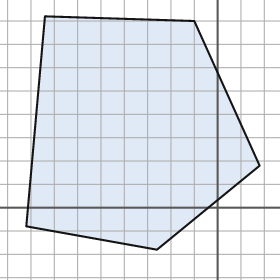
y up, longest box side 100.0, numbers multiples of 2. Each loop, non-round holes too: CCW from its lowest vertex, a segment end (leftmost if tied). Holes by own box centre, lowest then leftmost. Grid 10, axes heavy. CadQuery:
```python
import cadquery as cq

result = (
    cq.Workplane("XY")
    .moveTo(-26.0, -18.0)
    .lineTo(18.0, 18.0)
    .lineTo(-10.0, 80.0)
    .lineTo(-74.0, 82.0)
    .lineTo(-82.0, -8.0)
    .close()
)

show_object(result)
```